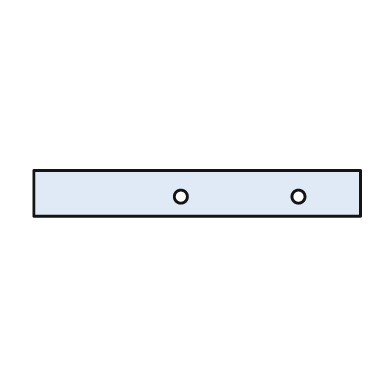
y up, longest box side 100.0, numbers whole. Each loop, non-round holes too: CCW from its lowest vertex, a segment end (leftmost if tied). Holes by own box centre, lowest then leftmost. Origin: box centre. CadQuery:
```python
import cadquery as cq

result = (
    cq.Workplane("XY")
    .moveTo(-50.0, -7.0)
    .lineTo(50.0, -7.0)
    .lineTo(50.0, 7.0)
    .lineTo(-50.0, 7.0)
    .close()
    .moveTo(-5.0, -1.0)
    .circle(2.0)
    .moveTo(31.0, -1.0)
    .circle(2.0)
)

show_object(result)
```